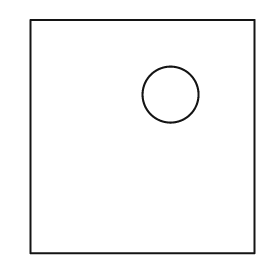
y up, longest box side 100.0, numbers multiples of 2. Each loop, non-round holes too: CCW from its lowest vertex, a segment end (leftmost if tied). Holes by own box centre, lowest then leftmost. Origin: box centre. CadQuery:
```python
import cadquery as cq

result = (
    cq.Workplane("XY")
    .moveTo(-48.0, -50.0)
    .lineTo(48.0, -50.0)
    .lineTo(48.0, 50.0)
    .lineTo(-48.0, 50.0)
    .close()
    .moveTo(12.0, 18.0)
    .circle(12.0)
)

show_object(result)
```